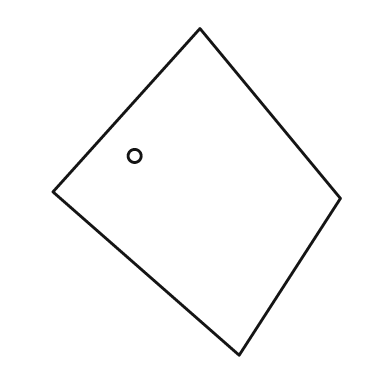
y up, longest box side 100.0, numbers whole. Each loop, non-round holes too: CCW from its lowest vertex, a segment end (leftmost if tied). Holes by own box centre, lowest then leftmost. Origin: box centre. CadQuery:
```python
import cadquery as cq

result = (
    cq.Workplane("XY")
    .moveTo(13.0, -50.0)
    .lineTo(44.0, -2.0)
    .lineTo(1.0, 50.0)
    .lineTo(-44.0, 0.0)
    .close()
    .moveTo(-19.0, 11.0)
    .circle(2.0)
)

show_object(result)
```